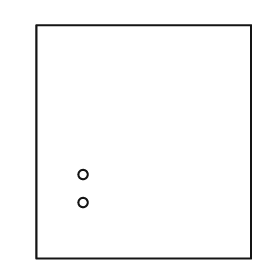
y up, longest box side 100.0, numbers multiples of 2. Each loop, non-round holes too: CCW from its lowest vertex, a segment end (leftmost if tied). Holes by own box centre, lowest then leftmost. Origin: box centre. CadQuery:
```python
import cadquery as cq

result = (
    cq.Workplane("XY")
    .moveTo(-46.0, -50.0)
    .lineTo(46.0, -50.0)
    .lineTo(46.0, 50.0)
    .lineTo(-46.0, 50.0)
    .close()
    .moveTo(-26.0, -26.0)
    .circle(2.0)
    .moveTo(-26.0, -14.0)
    .circle(2.0)
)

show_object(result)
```